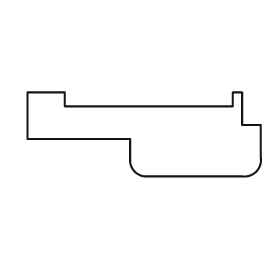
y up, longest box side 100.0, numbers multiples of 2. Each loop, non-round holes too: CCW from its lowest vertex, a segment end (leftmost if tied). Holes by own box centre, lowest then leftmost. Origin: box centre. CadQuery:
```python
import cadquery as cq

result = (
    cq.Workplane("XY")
    .moveTo(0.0, -18.0)
    .lineTo(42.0, -18.0)
    .threePointArc((48.0, -16.0), (50.0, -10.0))
    .lineTo(50.0, 4.0)
    .lineTo(42.0, 4.0)
    .lineTo(42.0, 18.0)
    .lineTo(38.0, 18.0)
    .lineTo(38.0, 12.0)
    .lineTo(-34.0, 12.0)
    .lineTo(-34.0, 18.0)
    .lineTo(-50.0, 18.0)
    .lineTo(-50.0, -2.0)
    .lineTo(-6.0, -2.0)
    .lineTo(-6.0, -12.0)
    .threePointArc((-4.0, -16.0), (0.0, -18.0))
    .close()
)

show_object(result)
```